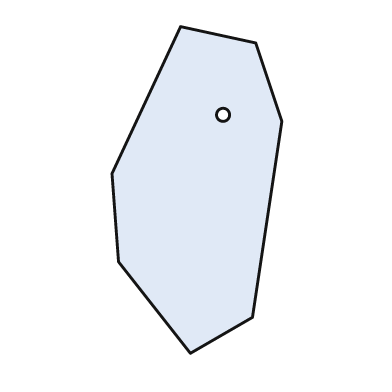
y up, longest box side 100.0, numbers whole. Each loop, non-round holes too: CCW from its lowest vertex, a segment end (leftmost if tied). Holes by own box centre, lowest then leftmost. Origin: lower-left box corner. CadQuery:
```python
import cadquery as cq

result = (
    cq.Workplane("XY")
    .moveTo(24.0, 0.0)
    .lineTo(43.0, 11.0)
    .lineTo(52.0, 71.0)
    .lineTo(44.0, 95.0)
    .lineTo(21.0, 100.0)
    .lineTo(0.0, 55.0)
    .lineTo(2.0, 28.0)
    .close()
    .moveTo(34.0, 73.0)
    .circle(2.0)
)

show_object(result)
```